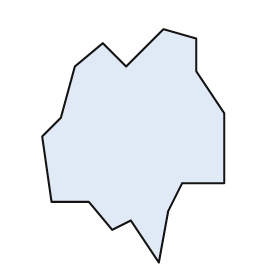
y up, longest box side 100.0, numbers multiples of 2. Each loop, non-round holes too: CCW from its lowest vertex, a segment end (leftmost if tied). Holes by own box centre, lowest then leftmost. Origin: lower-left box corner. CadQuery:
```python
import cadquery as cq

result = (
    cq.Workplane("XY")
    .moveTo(50.0, 0.0)
    .lineTo(54.0, 22.0)
    .lineTo(60.0, 34.0)
    .lineTo(78.0, 34.0)
    .lineTo(78.0, 64.0)
    .lineTo(66.0, 82.0)
    .lineTo(66.0, 96.0)
    .lineTo(52.0, 100.0)
    .lineTo(36.0, 84.0)
    .lineTo(26.0, 94.0)
    .lineTo(14.0, 84.0)
    .lineTo(8.0, 62.0)
    .lineTo(0.0, 54.0)
    .lineTo(4.0, 26.0)
    .lineTo(20.0, 26.0)
    .lineTo(30.0, 14.0)
    .lineTo(38.0, 18.0)
    .close()
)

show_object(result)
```